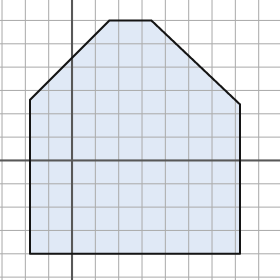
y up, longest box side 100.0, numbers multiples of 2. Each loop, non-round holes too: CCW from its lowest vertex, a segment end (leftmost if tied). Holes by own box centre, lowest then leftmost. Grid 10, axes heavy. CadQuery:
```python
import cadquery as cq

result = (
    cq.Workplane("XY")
    .moveTo(-18.0, -40.0)
    .lineTo(72.0, -40.0)
    .lineTo(72.0, 24.0)
    .lineTo(34.0, 60.0)
    .lineTo(16.0, 60.0)
    .lineTo(-18.0, 26.0)
    .close()
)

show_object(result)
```